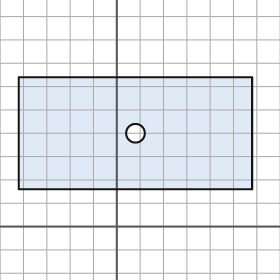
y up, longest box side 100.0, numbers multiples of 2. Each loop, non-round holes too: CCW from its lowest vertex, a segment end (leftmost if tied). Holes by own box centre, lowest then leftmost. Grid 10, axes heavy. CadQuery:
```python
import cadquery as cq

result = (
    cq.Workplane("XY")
    .moveTo(-42.0, 16.0)
    .lineTo(58.0, 16.0)
    .lineTo(58.0, 64.0)
    .lineTo(-42.0, 64.0)
    .close()
    .moveTo(8.0, 40.0)
    .circle(4.0)
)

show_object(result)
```